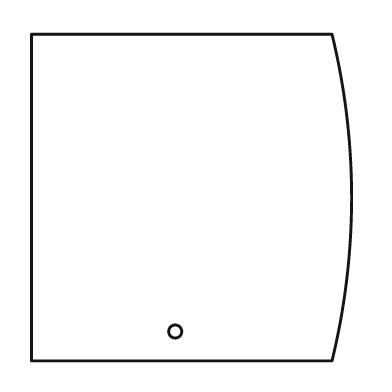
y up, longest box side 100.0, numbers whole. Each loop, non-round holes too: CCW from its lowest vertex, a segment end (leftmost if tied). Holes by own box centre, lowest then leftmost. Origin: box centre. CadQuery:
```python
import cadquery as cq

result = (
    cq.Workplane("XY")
    .moveTo(-49.0, -50.0)
    .lineTo(43.0, -50.0)
    .threePointArc((49.0, 0.0), (43.0, 50.0))
    .lineTo(-49.0, 50.0)
    .close()
    .moveTo(-5.0, -41.0)
    .circle(2.0)
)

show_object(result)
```